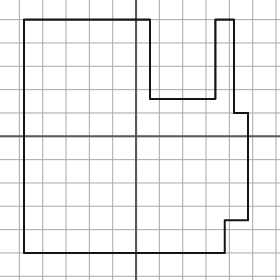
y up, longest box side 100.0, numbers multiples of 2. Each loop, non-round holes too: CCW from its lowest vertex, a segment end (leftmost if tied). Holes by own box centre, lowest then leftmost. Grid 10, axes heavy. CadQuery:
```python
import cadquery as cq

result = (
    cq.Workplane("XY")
    .moveTo(-48.0, -50.0)
    .lineTo(38.0, -50.0)
    .lineTo(38.0, -36.0)
    .lineTo(48.0, -36.0)
    .lineTo(48.0, 10.0)
    .lineTo(42.0, 10.0)
    .lineTo(42.0, 50.0)
    .lineTo(34.0, 50.0)
    .lineTo(34.0, 16.0)
    .lineTo(6.0, 16.0)
    .lineTo(6.0, 50.0)
    .lineTo(-48.0, 50.0)
    .close()
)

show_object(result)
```